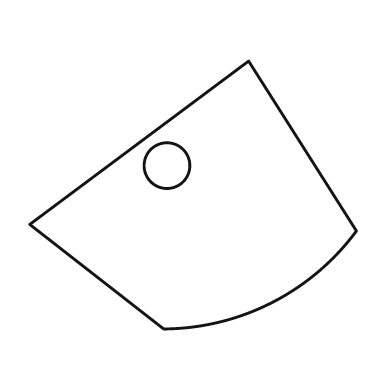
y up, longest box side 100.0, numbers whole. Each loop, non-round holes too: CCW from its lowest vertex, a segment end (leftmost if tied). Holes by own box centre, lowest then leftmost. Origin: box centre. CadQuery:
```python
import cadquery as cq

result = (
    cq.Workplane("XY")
    .moveTo(-9.0, -41.0)
    .threePointArc((24.0, -33.0), (50.0, -11.0))
    .lineTo(17.0, 41.0)
    .lineTo(-50.0, -9.0)
    .close()
    .moveTo(-8.0, 9.0)
    .circle(7.0)
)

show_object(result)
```